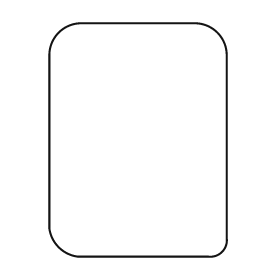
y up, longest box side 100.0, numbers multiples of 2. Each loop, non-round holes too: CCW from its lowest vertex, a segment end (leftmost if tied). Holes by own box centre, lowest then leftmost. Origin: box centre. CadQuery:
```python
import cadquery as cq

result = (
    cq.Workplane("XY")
    .moveTo(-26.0, -50.0)
    .lineTo(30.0, -50.0)
    .threePointArc((36.0, -48.0), (38.0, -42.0))
    .lineTo(38.0, 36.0)
    .threePointArc((34.0, 46.0), (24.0, 50.0))
    .lineTo(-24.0, 50.0)
    .threePointArc((-34.0, 46.0), (-38.0, 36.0))
    .lineTo(-38.0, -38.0)
    .threePointArc((-34.0, -46.0), (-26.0, -50.0))
    .close()
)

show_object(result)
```